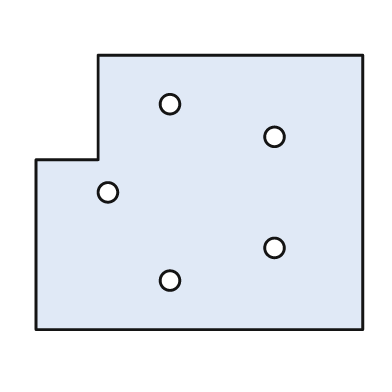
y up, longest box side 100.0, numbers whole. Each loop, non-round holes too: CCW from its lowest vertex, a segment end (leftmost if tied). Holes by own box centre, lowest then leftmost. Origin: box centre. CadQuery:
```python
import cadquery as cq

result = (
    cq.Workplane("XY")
    .moveTo(-50.0, -42.0)
    .lineTo(50.0, -42.0)
    .lineTo(50.0, 42.0)
    .lineTo(-31.0, 42.0)
    .lineTo(-31.0, 10.0)
    .lineTo(-50.0, 10.0)
    .close()
    .moveTo(-9.0, -27.0)
    .circle(3.0)
    .moveTo(23.0, -17.0)
    .circle(3.0)
    .moveTo(-28.0, 0.0)
    .circle(3.0)
    .moveTo(23.0, 17.0)
    .circle(3.0)
    .moveTo(-9.0, 27.0)
    .circle(3.0)
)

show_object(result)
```